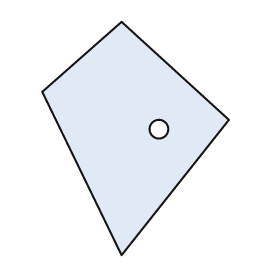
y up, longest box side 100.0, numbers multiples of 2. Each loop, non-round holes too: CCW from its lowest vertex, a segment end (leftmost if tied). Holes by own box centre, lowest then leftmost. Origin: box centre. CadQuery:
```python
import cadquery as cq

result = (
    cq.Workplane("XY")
    .moveTo(-6.0, -50.0)
    .lineTo(40.0, 8.0)
    .lineTo(-6.0, 50.0)
    .lineTo(-40.0, 20.0)
    .close()
    .moveTo(10.0, 4.0)
    .circle(4.0)
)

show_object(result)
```